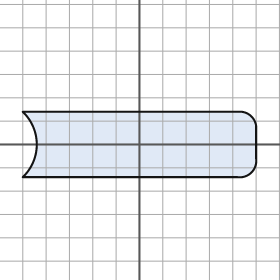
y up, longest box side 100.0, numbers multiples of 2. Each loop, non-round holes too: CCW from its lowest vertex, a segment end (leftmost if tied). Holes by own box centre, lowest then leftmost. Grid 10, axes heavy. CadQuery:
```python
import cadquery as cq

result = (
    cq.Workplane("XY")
    .moveTo(-50.0, -14.0)
    .lineTo(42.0, -14.0)
    .threePointArc((48.0, -12.0), (50.0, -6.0))
    .lineTo(50.0, 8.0)
    .threePointArc((48.0, 12.0), (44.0, 14.0))
    .lineTo(-50.0, 14.0)
    .threePointArc((-44.0, 0.0), (-50.0, -14.0))
    .close()
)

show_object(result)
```